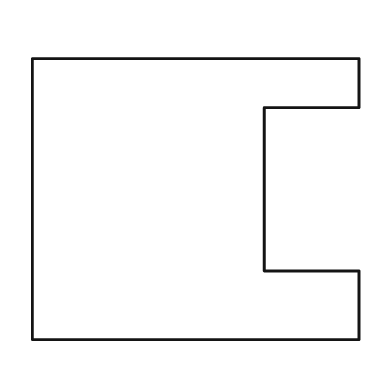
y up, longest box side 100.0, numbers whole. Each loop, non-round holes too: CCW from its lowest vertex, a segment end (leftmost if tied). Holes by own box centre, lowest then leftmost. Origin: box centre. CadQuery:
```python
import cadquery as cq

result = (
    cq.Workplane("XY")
    .moveTo(-50.0, -43.0)
    .lineTo(50.0, -43.0)
    .lineTo(50.0, -22.0)
    .lineTo(21.0, -22.0)
    .lineTo(21.0, 28.0)
    .lineTo(50.0, 28.0)
    .lineTo(50.0, 43.0)
    .lineTo(-50.0, 43.0)
    .close()
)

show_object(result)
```